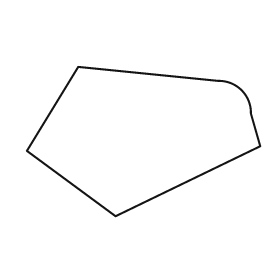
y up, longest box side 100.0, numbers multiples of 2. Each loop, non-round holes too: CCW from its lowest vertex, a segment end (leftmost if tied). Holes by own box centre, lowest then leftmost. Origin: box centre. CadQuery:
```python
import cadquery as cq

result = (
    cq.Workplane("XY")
    .moveTo(-12.0, -32.0)
    .lineTo(50.0, -2.0)
    .lineTo(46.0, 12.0)
    .threePointArc((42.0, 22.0), (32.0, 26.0))
    .lineTo(-28.0, 32.0)
    .lineTo(-50.0, -4.0)
    .close()
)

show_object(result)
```